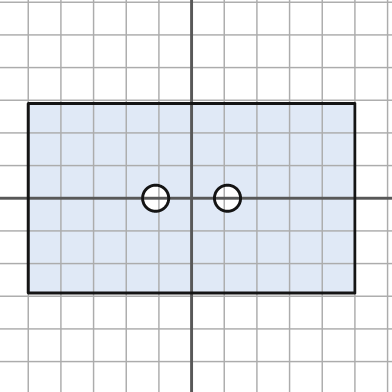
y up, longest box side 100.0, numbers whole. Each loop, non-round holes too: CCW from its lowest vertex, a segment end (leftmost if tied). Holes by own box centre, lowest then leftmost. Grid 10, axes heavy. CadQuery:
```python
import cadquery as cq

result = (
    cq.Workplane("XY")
    .moveTo(-50.0, -29.0)
    .lineTo(50.0, -29.0)
    .lineTo(50.0, 29.0)
    .lineTo(-50.0, 29.0)
    .close()
    .moveTo(-11.0, 0.0)
    .circle(4.0)
    .moveTo(11.0, 0.0)
    .circle(4.0)
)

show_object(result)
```